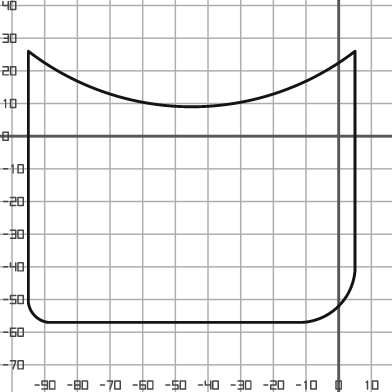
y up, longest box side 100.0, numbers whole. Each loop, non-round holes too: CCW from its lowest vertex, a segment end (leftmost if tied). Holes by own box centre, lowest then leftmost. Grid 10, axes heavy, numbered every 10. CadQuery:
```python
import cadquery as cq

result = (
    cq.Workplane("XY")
    .moveTo(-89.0, -57.0)
    .lineTo(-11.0, -57.0)
    .threePointArc((0.0, -52.0), (5.0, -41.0))
    .lineTo(5.0, 26.0)
    .threePointArc((-45.0, 9.0), (-95.0, 26.0))
    .lineTo(-95.0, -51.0)
    .threePointArc((-93.0, -55.0), (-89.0, -57.0))
    .close()
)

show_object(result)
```